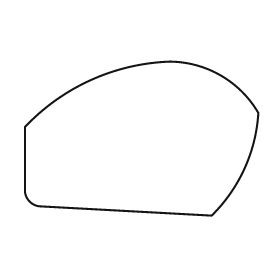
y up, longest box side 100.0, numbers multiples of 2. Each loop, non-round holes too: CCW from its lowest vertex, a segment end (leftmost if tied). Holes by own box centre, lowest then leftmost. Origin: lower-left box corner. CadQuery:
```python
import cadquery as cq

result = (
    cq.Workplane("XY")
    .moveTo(80.0, 0.0)
    .threePointArc((94.0, 20.0), (100.0, 44.0))
    .threePointArc((84.0, 60.0), (62.0, 66.0))
    .threePointArc((28.0, 58.0), (0.0, 38.0))
    .lineTo(0.0, 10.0)
    .threePointArc((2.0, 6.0), (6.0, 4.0))
    .close()
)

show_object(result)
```